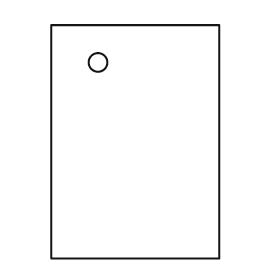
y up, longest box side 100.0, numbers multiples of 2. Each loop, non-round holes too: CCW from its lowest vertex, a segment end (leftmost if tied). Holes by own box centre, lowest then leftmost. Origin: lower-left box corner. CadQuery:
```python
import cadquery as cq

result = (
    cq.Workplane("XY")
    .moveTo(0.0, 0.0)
    .lineTo(72.0, 0.0)
    .lineTo(72.0, 100.0)
    .lineTo(0.0, 100.0)
    .close()
    .moveTo(20.0, 84.0)
    .circle(4.0)
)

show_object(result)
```